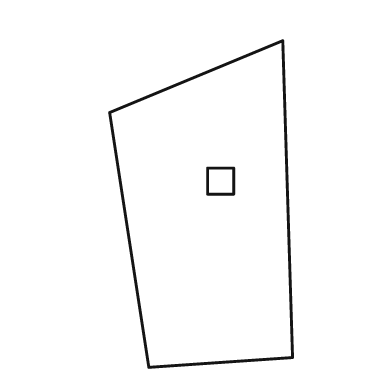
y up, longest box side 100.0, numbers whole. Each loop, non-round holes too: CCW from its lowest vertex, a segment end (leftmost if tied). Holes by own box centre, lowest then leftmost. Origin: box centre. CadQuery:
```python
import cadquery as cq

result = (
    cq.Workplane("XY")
    .moveTo(-16.0, -50.0)
    .lineTo(28.0, -47.0)
    .lineTo(25.0, 50.0)
    .lineTo(-28.0, 28.0)
    .close()
    .moveTo(2.0, 3.0)
    .lineTo(10.0, 3.0)
    .lineTo(10.0, 11.0)
    .lineTo(2.0, 11.0)
    .close()
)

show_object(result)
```